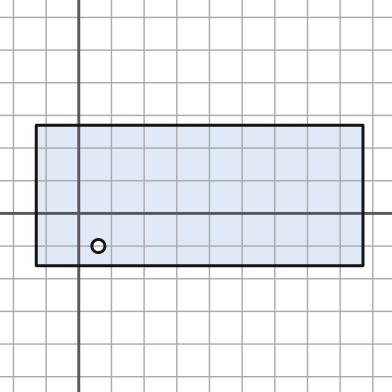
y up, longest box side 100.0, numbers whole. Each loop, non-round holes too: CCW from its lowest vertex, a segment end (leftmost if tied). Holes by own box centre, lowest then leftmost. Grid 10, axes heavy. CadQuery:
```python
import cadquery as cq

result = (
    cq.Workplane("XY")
    .moveTo(-13.0, -16.0)
    .lineTo(87.0, -16.0)
    .lineTo(87.0, 27.0)
    .lineTo(-13.0, 27.0)
    .close()
    .moveTo(6.0, -10.0)
    .circle(2.0)
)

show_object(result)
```